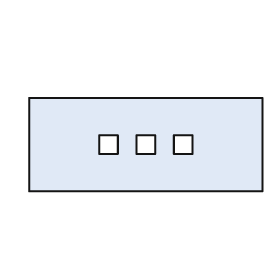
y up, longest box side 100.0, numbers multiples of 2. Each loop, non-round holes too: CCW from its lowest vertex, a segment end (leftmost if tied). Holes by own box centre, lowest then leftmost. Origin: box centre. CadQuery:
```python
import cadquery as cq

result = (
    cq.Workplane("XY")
    .moveTo(-50.0, -20.0)
    .lineTo(50.0, -20.0)
    .lineTo(50.0, 20.0)
    .lineTo(-50.0, 20.0)
    .close()
    .moveTo(-20.0, -4.0)
    .lineTo(-12.0, -4.0)
    .lineTo(-12.0, 4.0)
    .lineTo(-20.0, 4.0)
    .close()
    .moveTo(-4.0, -4.0)
    .lineTo(4.0, -4.0)
    .lineTo(4.0, 4.0)
    .lineTo(-4.0, 4.0)
    .close()
    .moveTo(12.0, -4.0)
    .lineTo(20.0, -4.0)
    .lineTo(20.0, 4.0)
    .lineTo(12.0, 4.0)
    .close()
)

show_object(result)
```